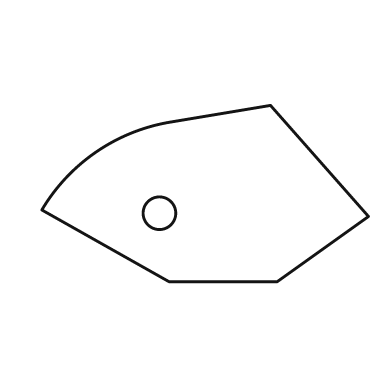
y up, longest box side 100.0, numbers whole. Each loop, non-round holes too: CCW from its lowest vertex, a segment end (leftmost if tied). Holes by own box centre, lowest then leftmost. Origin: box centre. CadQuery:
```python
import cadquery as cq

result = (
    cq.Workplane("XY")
    .moveTo(-11.0, -27.0)
    .lineTo(22.0, -27.0)
    .lineTo(50.0, -7.0)
    .lineTo(20.0, 27.0)
    .lineTo(-10.0, 22.0)
    .threePointArc((-33.0, 13.0), (-50.0, -5.0))
    .close()
    .moveTo(-14.0, -6.0)
    .circle(5.0)
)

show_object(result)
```